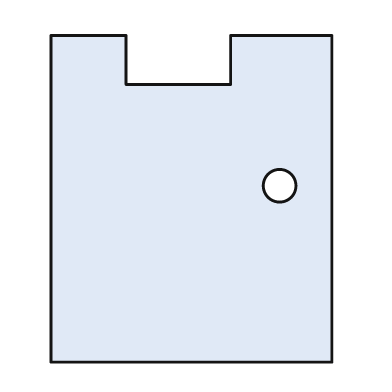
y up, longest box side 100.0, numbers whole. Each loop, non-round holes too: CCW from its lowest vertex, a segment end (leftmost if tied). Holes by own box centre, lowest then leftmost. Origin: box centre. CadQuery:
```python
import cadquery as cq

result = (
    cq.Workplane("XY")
    .moveTo(-43.0, -50.0)
    .lineTo(43.0, -50.0)
    .lineTo(43.0, 50.0)
    .lineTo(12.0, 50.0)
    .lineTo(12.0, 35.0)
    .lineTo(-20.0, 35.0)
    .lineTo(-20.0, 50.0)
    .lineTo(-43.0, 50.0)
    .close()
    .moveTo(27.0, 4.0)
    .circle(5.0)
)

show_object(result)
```